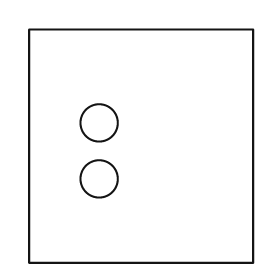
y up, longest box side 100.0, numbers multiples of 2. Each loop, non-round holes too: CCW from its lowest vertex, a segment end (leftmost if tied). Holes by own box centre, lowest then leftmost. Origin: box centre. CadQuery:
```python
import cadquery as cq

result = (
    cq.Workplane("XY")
    .moveTo(-48.0, -50.0)
    .lineTo(48.0, -50.0)
    .lineTo(48.0, 50.0)
    .lineTo(-48.0, 50.0)
    .close()
    .moveTo(-18.0, -14.0)
    .circle(8.0)
    .moveTo(-18.0, 10.0)
    .circle(8.0)
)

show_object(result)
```